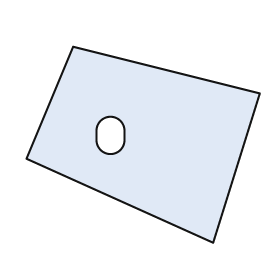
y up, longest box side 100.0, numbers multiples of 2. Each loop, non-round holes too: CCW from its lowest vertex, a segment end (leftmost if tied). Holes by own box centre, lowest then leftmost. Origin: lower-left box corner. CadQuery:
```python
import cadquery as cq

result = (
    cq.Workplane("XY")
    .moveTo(80.0, 0.0)
    .lineTo(100.0, 64.0)
    .lineTo(20.0, 84.0)
    .lineTo(0.0, 36.0)
    .close()
    .moveTo(30.0, 44.0)
    .threePointArc((36.0, 38.0), (42.0, 44.0))
    .lineTo(42.0, 48.0)
    .threePointArc((36.0, 54.0), (30.0, 48.0))
    .close()
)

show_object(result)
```